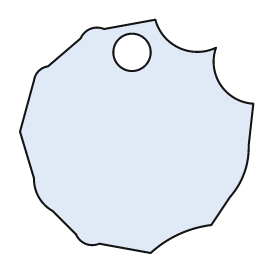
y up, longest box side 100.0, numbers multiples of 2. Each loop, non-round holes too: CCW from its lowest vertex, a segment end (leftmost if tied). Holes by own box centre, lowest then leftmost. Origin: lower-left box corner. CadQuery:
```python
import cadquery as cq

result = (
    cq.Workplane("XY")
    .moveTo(56.0, 0.0)
    .threePointArc((68.0, 8.0), (82.0, 12.0))
    .lineTo(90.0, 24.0)
    .threePointArc((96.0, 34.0), (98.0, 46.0))
    .lineTo(100.0, 64.0)
    .threePointArc((86.0, 72.0), (84.0, 88.0))
    .threePointArc((68.0, 88.0), (58.0, 100.0))
    .lineTo(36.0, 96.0)
    .threePointArc((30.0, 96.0), (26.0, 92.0))
    .lineTo(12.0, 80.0)
    .threePointArc((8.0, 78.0), (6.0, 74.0))
    .lineTo(0.0, 52.0)
    .lineTo(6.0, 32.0)
    .threePointArc((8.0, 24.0), (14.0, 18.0))
    .lineTo(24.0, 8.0)
    .threePointArc((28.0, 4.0), (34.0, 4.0))
    .close()
    .moveTo(48.0, 86.0)
    .circle(8.0)
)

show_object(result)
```